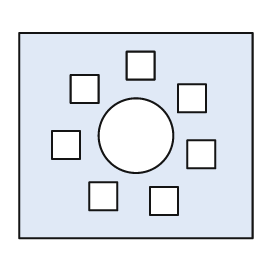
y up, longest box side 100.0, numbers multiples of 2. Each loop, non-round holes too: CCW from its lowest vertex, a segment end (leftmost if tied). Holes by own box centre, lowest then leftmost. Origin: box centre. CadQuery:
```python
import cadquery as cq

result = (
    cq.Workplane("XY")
    .moveTo(-50.0, -44.0)
    .lineTo(50.0, -44.0)
    .lineTo(50.0, 44.0)
    .lineTo(-50.0, 44.0)
    .close()
    .moveTo(6.0, -34.0)
    .lineTo(18.0, -34.0)
    .lineTo(18.0, -22.0)
    .lineTo(6.0, -22.0)
    .close()
    .moveTo(-20.0, -32.0)
    .lineTo(-8.0, -32.0)
    .lineTo(-8.0, -20.0)
    .lineTo(-20.0, -20.0)
    .close()
    .moveTo(22.0, -14.0)
    .lineTo(34.0, -14.0)
    .lineTo(34.0, -2.0)
    .lineTo(22.0, -2.0)
    .close()
    .moveTo(-36.0, -10.0)
    .lineTo(-24.0, -10.0)
    .lineTo(-24.0, 2.0)
    .lineTo(-36.0, 2.0)
    .close()
    .moveTo(0.0, 0.0)
    .circle(16.0)
    .moveTo(18.0, 10.0)
    .lineTo(30.0, 10.0)
    .lineTo(30.0, 22.0)
    .lineTo(18.0, 22.0)
    .close()
    .moveTo(-28.0, 14.0)
    .lineTo(-16.0, 14.0)
    .lineTo(-16.0, 26.0)
    .lineTo(-28.0, 26.0)
    .close()
    .moveTo(-4.0, 24.0)
    .lineTo(8.0, 24.0)
    .lineTo(8.0, 36.0)
    .lineTo(-4.0, 36.0)
    .close()
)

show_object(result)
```